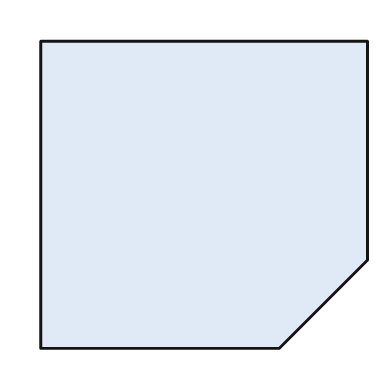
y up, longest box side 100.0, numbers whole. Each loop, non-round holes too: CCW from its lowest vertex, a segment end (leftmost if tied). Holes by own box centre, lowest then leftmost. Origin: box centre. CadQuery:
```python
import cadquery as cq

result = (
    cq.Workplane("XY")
    .moveTo(-50.0, -47.0)
    .lineTo(23.0, -47.0)
    .lineTo(50.0, -20.0)
    .lineTo(50.0, 47.0)
    .lineTo(-50.0, 47.0)
    .close()
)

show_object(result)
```